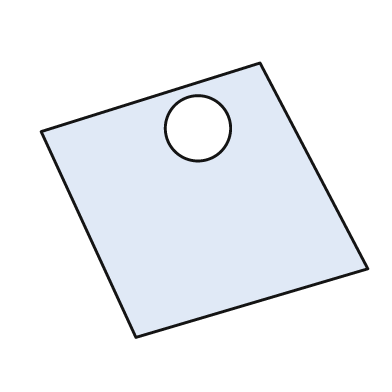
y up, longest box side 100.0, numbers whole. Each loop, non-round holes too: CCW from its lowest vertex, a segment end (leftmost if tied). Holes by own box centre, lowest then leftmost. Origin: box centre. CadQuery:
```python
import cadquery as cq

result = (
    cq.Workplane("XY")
    .moveTo(-21.0, -42.0)
    .lineTo(50.0, -21.0)
    .lineTo(17.0, 42.0)
    .lineTo(-50.0, 21.0)
    .close()
    .moveTo(-2.0, 22.0)
    .circle(10.0)
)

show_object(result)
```